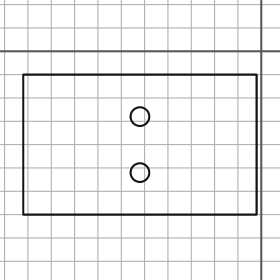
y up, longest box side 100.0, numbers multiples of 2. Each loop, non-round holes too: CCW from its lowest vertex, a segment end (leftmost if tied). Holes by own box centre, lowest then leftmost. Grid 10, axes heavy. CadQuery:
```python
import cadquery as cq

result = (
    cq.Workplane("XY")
    .moveTo(-102.0, -70.0)
    .lineTo(-2.0, -70.0)
    .lineTo(-2.0, -10.0)
    .lineTo(-102.0, -10.0)
    .close()
    .moveTo(-52.0, -52.0)
    .circle(4.0)
    .moveTo(-52.0, -28.0)
    .circle(4.0)
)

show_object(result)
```